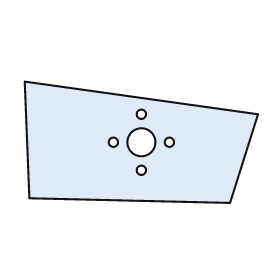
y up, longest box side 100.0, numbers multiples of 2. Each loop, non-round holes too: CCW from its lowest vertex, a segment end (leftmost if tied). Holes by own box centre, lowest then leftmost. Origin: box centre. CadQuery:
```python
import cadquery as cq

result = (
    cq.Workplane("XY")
    .moveTo(38.0, -26.0)
    .lineTo(50.0, 12.0)
    .lineTo(-50.0, 26.0)
    .lineTo(-48.0, -24.0)
    .close()
    .moveTo(0.0, -12.0)
    .circle(2.0)
    .moveTo(-12.0, 0.0)
    .circle(2.0)
    .moveTo(0.0, 0.0)
    .circle(6.0)
    .moveTo(12.0, 0.0)
    .circle(2.0)
    .moveTo(0.0, 12.0)
    .circle(2.0)
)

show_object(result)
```